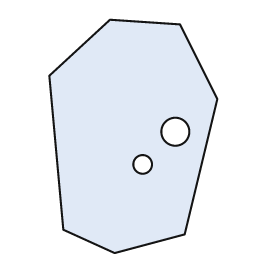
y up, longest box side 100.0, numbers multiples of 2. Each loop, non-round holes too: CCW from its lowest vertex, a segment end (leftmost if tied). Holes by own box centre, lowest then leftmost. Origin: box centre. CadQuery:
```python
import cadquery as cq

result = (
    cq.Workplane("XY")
    .moveTo(-8.0, -50.0)
    .lineTo(22.0, -42.0)
    .lineTo(36.0, 16.0)
    .lineTo(20.0, 48.0)
    .lineTo(-10.0, 50.0)
    .lineTo(-36.0, 26.0)
    .lineTo(-30.0, -40.0)
    .close()
    .moveTo(4.0, -12.0)
    .circle(4.0)
    .moveTo(18.0, 2.0)
    .circle(6.0)
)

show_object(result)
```